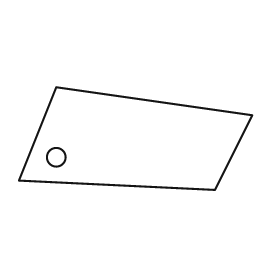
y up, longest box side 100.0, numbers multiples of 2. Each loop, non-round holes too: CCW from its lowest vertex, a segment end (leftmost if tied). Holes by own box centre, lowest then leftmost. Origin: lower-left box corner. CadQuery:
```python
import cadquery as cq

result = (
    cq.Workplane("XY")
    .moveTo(84.0, 0.0)
    .lineTo(100.0, 32.0)
    .lineTo(16.0, 44.0)
    .lineTo(0.0, 4.0)
    .close()
    .moveTo(16.0, 14.0)
    .circle(4.0)
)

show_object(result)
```